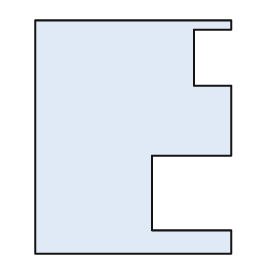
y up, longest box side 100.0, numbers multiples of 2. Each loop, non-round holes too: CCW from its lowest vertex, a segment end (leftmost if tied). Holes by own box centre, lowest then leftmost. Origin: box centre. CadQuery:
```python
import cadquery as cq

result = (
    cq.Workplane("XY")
    .moveTo(-42.0, -50.0)
    .lineTo(42.0, -50.0)
    .lineTo(42.0, -40.0)
    .lineTo(8.0, -40.0)
    .lineTo(8.0, -8.0)
    .lineTo(42.0, -8.0)
    .lineTo(42.0, 22.0)
    .lineTo(26.0, 22.0)
    .lineTo(26.0, 46.0)
    .lineTo(42.0, 46.0)
    .lineTo(42.0, 50.0)
    .lineTo(-42.0, 50.0)
    .close()
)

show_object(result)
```